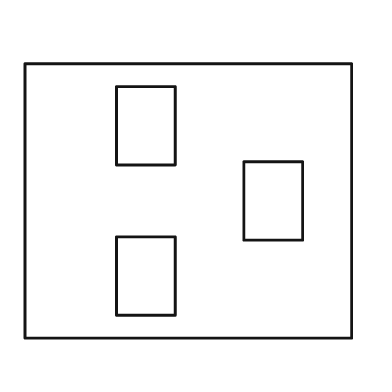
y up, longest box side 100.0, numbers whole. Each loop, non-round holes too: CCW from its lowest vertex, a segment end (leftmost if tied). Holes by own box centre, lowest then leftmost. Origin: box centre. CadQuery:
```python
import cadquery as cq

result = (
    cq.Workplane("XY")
    .moveTo(-50.0, -42.0)
    .lineTo(50.0, -42.0)
    .lineTo(50.0, 42.0)
    .lineTo(-50.0, 42.0)
    .close()
    .moveTo(-22.0, -35.0)
    .lineTo(-4.0, -35.0)
    .lineTo(-4.0, -11.0)
    .lineTo(-22.0, -11.0)
    .close()
    .moveTo(17.0, -12.0)
    .lineTo(35.0, -12.0)
    .lineTo(35.0, 12.0)
    .lineTo(17.0, 12.0)
    .close()
    .moveTo(-22.0, 11.0)
    .lineTo(-4.0, 11.0)
    .lineTo(-4.0, 35.0)
    .lineTo(-22.0, 35.0)
    .close()
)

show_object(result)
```